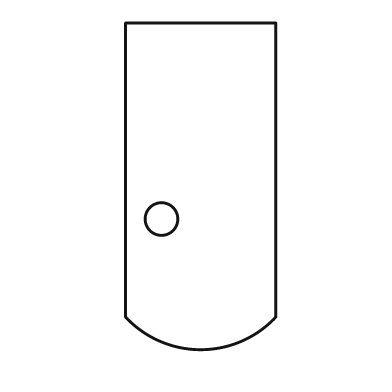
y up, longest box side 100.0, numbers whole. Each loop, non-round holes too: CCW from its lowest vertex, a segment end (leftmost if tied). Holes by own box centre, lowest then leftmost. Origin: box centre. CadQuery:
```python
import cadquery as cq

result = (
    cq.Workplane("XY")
    .moveTo(-23.0, -40.0)
    .threePointArc((0.0, -50.0), (23.0, -40.0))
    .lineTo(23.0, 50.0)
    .lineTo(-23.0, 50.0)
    .close()
    .moveTo(-12.0, -10.0)
    .circle(5.0)
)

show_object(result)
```